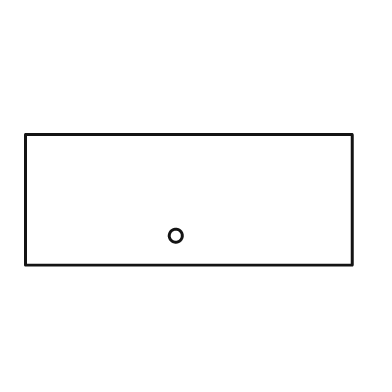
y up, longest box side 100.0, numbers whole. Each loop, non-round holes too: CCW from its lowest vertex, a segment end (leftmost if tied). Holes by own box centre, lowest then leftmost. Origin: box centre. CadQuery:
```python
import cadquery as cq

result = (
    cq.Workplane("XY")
    .moveTo(-50.0, -20.0)
    .lineTo(50.0, -20.0)
    .lineTo(50.0, 20.0)
    .lineTo(-50.0, 20.0)
    .close()
    .moveTo(-4.0, -11.0)
    .circle(2.0)
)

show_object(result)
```